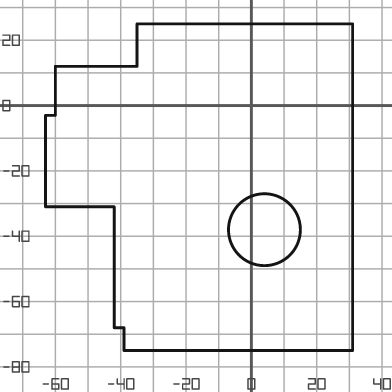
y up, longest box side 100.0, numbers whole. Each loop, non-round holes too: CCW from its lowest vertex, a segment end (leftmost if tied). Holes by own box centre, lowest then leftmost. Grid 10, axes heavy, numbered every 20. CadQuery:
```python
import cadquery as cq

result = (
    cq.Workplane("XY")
    .moveTo(-39.0, -75.0)
    .lineTo(31.0, -75.0)
    .lineTo(31.0, 25.0)
    .lineTo(-35.0, 25.0)
    .lineTo(-35.0, 12.0)
    .lineTo(-60.0, 12.0)
    .lineTo(-60.0, -3.0)
    .lineTo(-63.0, -3.0)
    .lineTo(-63.0, -31.0)
    .lineTo(-42.0, -31.0)
    .lineTo(-42.0, -68.0)
    .lineTo(-39.0, -68.0)
    .close()
    .moveTo(4.0, -38.0)
    .circle(11.0)
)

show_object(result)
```